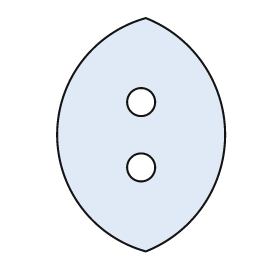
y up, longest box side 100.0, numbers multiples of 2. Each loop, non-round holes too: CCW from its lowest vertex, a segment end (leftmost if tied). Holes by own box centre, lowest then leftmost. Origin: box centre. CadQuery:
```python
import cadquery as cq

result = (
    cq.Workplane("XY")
    .moveTo(2.0, -50.0)
    .threePointArc((36.0, 0.0), (2.0, 50.0))
    .threePointArc((-36.0, 0.0), (2.0, -50.0))
    .close()
    .moveTo(0.0, -14.0)
    .circle(6.0)
    .moveTo(0.0, 14.0)
    .circle(6.0)
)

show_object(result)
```